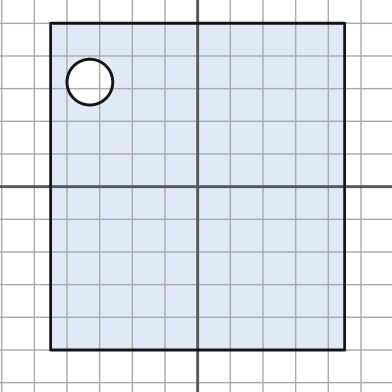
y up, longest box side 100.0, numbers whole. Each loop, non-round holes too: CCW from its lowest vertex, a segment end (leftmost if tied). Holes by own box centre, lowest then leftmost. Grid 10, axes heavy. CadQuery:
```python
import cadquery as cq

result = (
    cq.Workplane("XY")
    .moveTo(-45.0, -50.0)
    .lineTo(45.0, -50.0)
    .lineTo(45.0, 50.0)
    .lineTo(-45.0, 50.0)
    .close()
    .moveTo(-33.0, 32.0)
    .circle(7.0)
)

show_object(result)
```